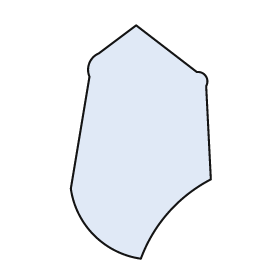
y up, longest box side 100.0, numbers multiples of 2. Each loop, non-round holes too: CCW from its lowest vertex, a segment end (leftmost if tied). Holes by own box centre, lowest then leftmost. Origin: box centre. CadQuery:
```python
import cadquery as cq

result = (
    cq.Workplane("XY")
    .moveTo(0.0, -50.0)
    .threePointArc((12.0, -30.0), (30.0, -16.0))
    .lineTo(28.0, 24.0)
    .threePointArc((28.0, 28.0), (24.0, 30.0))
    .lineTo(-2.0, 50.0)
    .lineTo(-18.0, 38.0)
    .threePointArc((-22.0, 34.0), (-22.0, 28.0))
    .lineTo(-30.0, -20.0)
    .threePointArc((-20.0, -40.0), (0.0, -50.0))
    .close()
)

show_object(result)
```